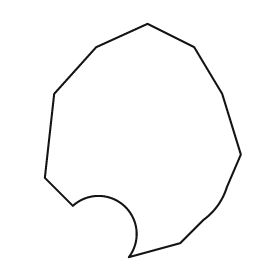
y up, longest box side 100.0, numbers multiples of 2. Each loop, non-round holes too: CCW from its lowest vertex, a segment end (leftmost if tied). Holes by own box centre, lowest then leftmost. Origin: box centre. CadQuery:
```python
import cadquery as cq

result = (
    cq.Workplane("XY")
    .moveTo(-6.0, -50.0)
    .lineTo(16.0, -44.0)
    .lineTo(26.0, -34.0)
    .threePointArc((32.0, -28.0), (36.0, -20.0))
    .lineTo(42.0, -6.0)
    .lineTo(34.0, 20.0)
    .lineTo(22.0, 40.0)
    .lineTo(2.0, 50.0)
    .lineTo(-20.0, 40.0)
    .lineTo(-38.0, 20.0)
    .lineTo(-42.0, -16.0)
    .lineTo(-30.0, -28.0)
    .threePointArc((-8.0, -28.0), (-6.0, -50.0))
    .close()
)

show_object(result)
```